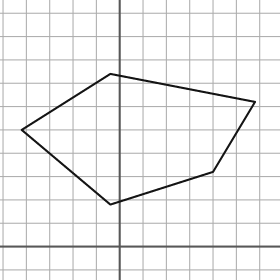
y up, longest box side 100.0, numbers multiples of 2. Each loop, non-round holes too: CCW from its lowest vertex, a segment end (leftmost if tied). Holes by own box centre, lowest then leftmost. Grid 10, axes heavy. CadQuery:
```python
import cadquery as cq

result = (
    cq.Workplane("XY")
    .moveTo(-4.0, 18.0)
    .lineTo(40.0, 32.0)
    .lineTo(58.0, 62.0)
    .lineTo(-4.0, 74.0)
    .lineTo(-42.0, 50.0)
    .close()
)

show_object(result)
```